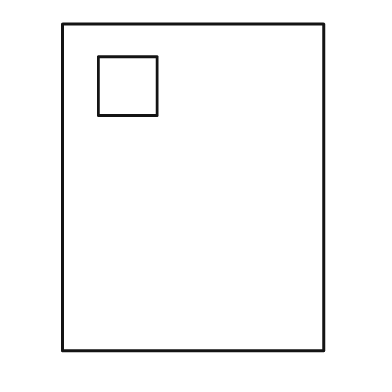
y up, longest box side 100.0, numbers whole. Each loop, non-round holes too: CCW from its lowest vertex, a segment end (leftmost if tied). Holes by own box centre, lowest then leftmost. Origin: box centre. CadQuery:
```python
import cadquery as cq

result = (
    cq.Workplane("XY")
    .moveTo(-40.0, -50.0)
    .lineTo(40.0, -50.0)
    .lineTo(40.0, 50.0)
    .lineTo(-40.0, 50.0)
    .close()
    .moveTo(-29.0, 22.0)
    .lineTo(-11.0, 22.0)
    .lineTo(-11.0, 40.0)
    .lineTo(-29.0, 40.0)
    .close()
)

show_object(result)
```